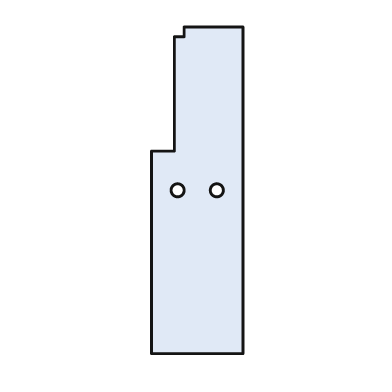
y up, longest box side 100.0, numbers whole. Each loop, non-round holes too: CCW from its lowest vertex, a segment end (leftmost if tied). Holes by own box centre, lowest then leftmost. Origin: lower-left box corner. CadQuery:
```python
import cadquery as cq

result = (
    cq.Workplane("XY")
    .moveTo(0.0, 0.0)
    .lineTo(28.0, 0.0)
    .lineTo(28.0, 100.0)
    .lineTo(10.0, 100.0)
    .lineTo(10.0, 97.0)
    .lineTo(7.0, 97.0)
    .lineTo(7.0, 62.0)
    .lineTo(0.0, 62.0)
    .close()
    .moveTo(8.0, 50.0)
    .circle(2.0)
    .moveTo(20.0, 50.0)
    .circle(2.0)
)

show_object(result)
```